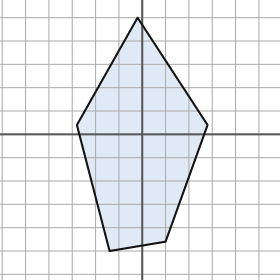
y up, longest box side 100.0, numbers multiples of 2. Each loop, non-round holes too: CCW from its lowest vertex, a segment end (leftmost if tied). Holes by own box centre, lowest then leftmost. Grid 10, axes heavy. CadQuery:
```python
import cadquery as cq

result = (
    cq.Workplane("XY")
    .moveTo(-14.0, -50.0)
    .lineTo(10.0, -46.0)
    .lineTo(28.0, 4.0)
    .lineTo(-2.0, 50.0)
    .lineTo(-28.0, 4.0)
    .close()
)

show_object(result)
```